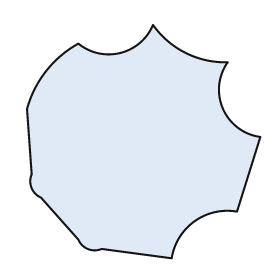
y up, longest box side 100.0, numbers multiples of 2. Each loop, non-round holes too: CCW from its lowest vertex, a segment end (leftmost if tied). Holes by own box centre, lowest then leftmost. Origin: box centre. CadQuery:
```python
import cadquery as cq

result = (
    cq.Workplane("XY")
    .moveTo(12.0, -50.0)
    .threePointArc((22.0, -34.0), (40.0, -30.0))
    .lineTo(50.0, 2.0)
    .threePointArc((34.0, 14.0), (36.0, 34.0))
    .threePointArc((18.0, 38.0), (4.0, 50.0))
    .threePointArc((-10.0, 38.0), (-28.0, 42.0))
    .threePointArc((-42.0, 30.0), (-50.0, 14.0))
    .lineTo(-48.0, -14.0)
    .threePointArc((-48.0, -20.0), (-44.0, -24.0))
    .lineTo(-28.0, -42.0)
    .threePointArc((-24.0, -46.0), (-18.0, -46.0))
    .close()
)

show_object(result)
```